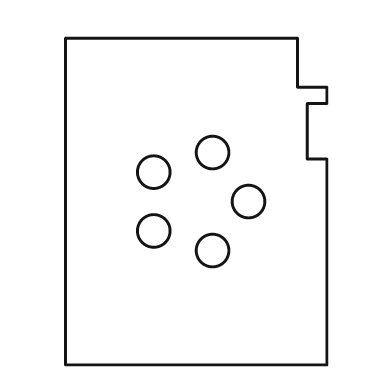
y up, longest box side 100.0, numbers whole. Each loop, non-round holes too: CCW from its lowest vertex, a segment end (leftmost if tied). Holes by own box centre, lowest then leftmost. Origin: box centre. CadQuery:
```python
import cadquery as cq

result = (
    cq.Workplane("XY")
    .moveTo(-40.0, -50.0)
    .lineTo(40.0, -50.0)
    .lineTo(40.0, 13.0)
    .lineTo(34.0, 13.0)
    .lineTo(34.0, 30.0)
    .lineTo(40.0, 30.0)
    .lineTo(40.0, 35.0)
    .lineTo(31.0, 35.0)
    .lineTo(31.0, 50.0)
    .lineTo(-40.0, 50.0)
    .close()
    .moveTo(5.0, -15.0)
    .circle(5.0)
    .moveTo(-13.0, -9.0)
    .circle(5.0)
    .moveTo(16.0, 0.0)
    .circle(5.0)
    .moveTo(-13.0, 9.0)
    .circle(5.0)
    .moveTo(5.0, 15.0)
    .circle(5.0)
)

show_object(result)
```